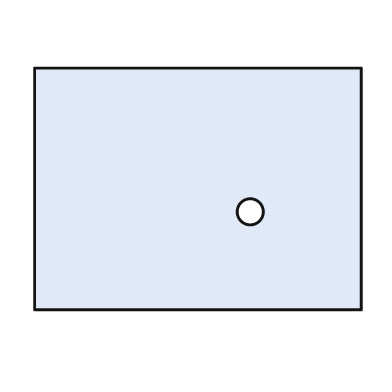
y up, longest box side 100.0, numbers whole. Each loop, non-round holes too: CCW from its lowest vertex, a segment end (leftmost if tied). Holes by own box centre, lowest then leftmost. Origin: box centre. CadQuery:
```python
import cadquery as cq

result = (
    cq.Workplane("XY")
    .moveTo(-50.0, -37.0)
    .lineTo(50.0, -37.0)
    .lineTo(50.0, 37.0)
    .lineTo(-50.0, 37.0)
    .close()
    .moveTo(16.0, -7.0)
    .circle(4.0)
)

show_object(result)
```